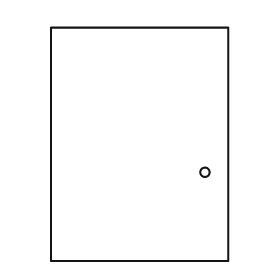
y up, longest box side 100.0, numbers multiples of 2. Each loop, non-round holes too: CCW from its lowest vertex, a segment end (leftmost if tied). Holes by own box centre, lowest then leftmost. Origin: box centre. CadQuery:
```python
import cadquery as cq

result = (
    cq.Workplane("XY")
    .moveTo(-38.0, -50.0)
    .lineTo(38.0, -50.0)
    .lineTo(38.0, 50.0)
    .lineTo(-38.0, 50.0)
    .close()
    .moveTo(28.0, -12.0)
    .circle(2.0)
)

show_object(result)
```